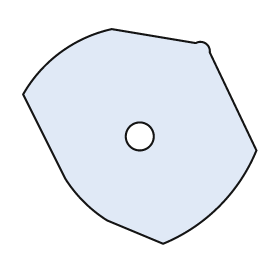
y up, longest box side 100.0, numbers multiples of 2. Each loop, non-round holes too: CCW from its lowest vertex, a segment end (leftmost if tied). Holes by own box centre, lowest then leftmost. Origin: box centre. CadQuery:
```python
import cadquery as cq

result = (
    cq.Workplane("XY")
    .moveTo(10.0, -46.0)
    .threePointArc((34.0, -30.0), (50.0, -6.0))
    .lineTo(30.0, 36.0)
    .threePointArc((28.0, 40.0), (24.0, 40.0))
    .lineTo(-12.0, 46.0)
    .threePointArc((-34.0, 36.0), (-50.0, 18.0))
    .lineTo(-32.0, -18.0)
    .threePointArc((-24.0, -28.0), (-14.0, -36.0))
    .close()
    .moveTo(0.0, 0.0)
    .circle(6.0)
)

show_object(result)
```